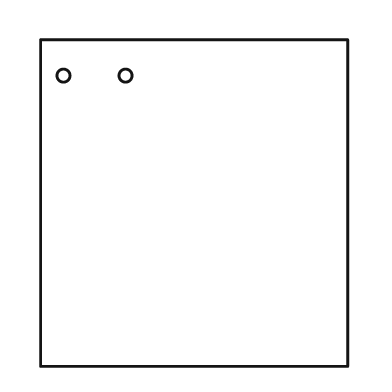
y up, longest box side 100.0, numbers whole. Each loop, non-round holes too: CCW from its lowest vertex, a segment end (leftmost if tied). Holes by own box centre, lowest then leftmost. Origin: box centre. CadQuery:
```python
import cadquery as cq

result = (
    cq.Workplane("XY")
    .moveTo(-47.0, -50.0)
    .lineTo(47.0, -50.0)
    .lineTo(47.0, 50.0)
    .lineTo(-47.0, 50.0)
    .close()
    .moveTo(-40.0, 39.0)
    .circle(2.0)
    .moveTo(-21.0, 39.0)
    .circle(2.0)
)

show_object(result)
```